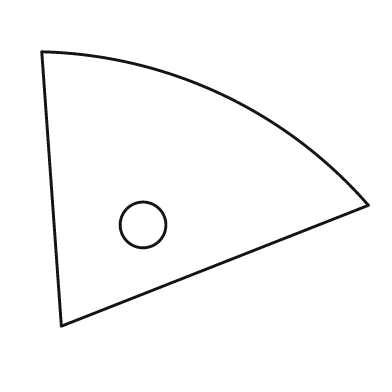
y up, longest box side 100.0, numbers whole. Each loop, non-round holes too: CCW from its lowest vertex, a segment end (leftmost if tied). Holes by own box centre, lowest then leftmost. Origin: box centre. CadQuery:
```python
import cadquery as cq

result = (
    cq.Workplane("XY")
    .moveTo(-44.0, -42.0)
    .lineTo(50.0, -5.0)
    .threePointArc((5.0, 29.0), (-50.0, 42.0))
    .close()
    .moveTo(-19.0, -11.0)
    .circle(7.0)
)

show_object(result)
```